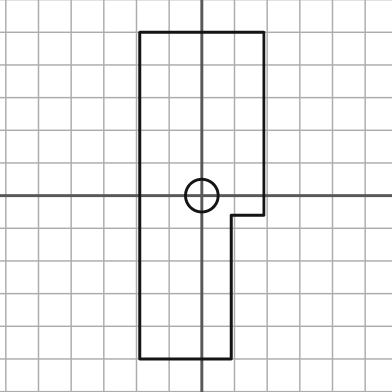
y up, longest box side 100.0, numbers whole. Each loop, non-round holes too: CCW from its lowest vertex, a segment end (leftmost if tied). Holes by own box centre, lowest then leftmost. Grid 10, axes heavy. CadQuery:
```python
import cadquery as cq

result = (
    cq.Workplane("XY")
    .moveTo(-19.0, -50.0)
    .lineTo(9.0, -50.0)
    .lineTo(9.0, -6.0)
    .lineTo(19.0, -6.0)
    .lineTo(19.0, 50.0)
    .lineTo(-19.0, 50.0)
    .close()
    .moveTo(0.0, 0.0)
    .circle(5.0)
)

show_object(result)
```